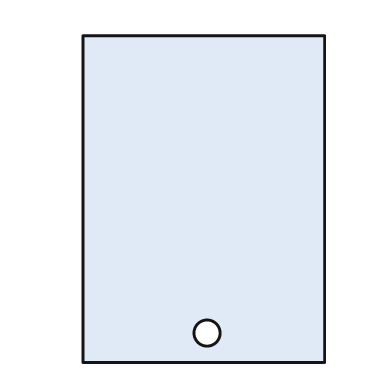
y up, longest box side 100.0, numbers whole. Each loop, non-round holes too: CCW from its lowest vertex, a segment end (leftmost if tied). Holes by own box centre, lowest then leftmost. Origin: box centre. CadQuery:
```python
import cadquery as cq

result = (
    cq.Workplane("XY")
    .moveTo(-37.0, -50.0)
    .lineTo(37.0, -50.0)
    .lineTo(37.0, 50.0)
    .lineTo(-37.0, 50.0)
    .close()
    .moveTo(1.0, -41.0)
    .circle(4.0)
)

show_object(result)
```